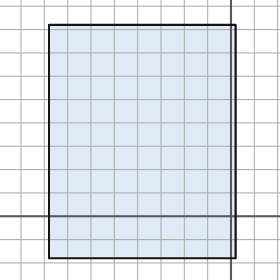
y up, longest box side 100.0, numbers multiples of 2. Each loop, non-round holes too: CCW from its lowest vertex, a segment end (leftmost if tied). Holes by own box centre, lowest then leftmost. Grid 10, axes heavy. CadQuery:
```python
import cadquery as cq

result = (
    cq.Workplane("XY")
    .moveTo(-78.0, -18.0)
    .lineTo(2.0, -18.0)
    .lineTo(2.0, 82.0)
    .lineTo(-78.0, 82.0)
    .close()
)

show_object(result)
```